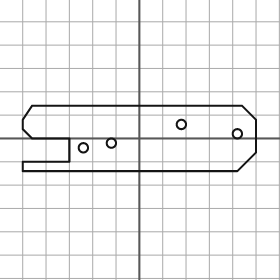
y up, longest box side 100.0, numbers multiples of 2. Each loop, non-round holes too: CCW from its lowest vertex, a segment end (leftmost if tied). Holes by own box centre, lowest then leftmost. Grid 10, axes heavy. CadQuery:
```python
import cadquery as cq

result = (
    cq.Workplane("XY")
    .moveTo(-50.0, -14.0)
    .lineTo(42.0, -14.0)
    .lineTo(50.0, -6.0)
    .lineTo(50.0, 8.0)
    .lineTo(44.0, 14.0)
    .lineTo(-46.0, 14.0)
    .lineTo(-50.0, 8.0)
    .lineTo(-50.0, 4.0)
    .lineTo(-46.0, 0.0)
    .lineTo(-30.0, 0.0)
    .lineTo(-30.0, -10.0)
    .lineTo(-50.0, -10.0)
    .close()
    .moveTo(-24.0, -4.0)
    .circle(2.0)
    .moveTo(-12.0, -2.0)
    .circle(2.0)
    .moveTo(42.0, 2.0)
    .circle(2.0)
    .moveTo(18.0, 6.0)
    .circle(2.0)
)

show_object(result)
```